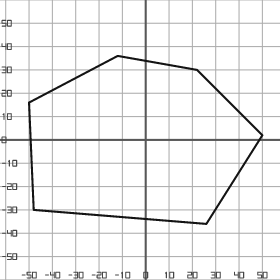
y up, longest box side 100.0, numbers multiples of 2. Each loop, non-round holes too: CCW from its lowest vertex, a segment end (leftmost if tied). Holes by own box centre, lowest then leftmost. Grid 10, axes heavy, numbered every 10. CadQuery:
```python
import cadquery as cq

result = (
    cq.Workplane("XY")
    .moveTo(26.0, -36.0)
    .lineTo(50.0, 2.0)
    .lineTo(22.0, 30.0)
    .lineTo(-12.0, 36.0)
    .lineTo(-50.0, 16.0)
    .lineTo(-48.0, -30.0)
    .close()
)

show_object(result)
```